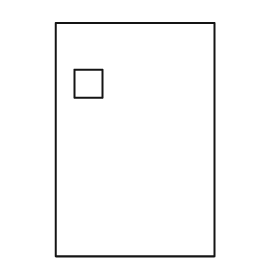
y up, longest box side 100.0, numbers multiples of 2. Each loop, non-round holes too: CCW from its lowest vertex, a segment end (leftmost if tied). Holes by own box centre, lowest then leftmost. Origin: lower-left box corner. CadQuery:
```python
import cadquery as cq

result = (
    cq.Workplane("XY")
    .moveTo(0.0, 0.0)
    .lineTo(68.0, 0.0)
    .lineTo(68.0, 100.0)
    .lineTo(0.0, 100.0)
    .close()
    .moveTo(8.0, 68.0)
    .lineTo(20.0, 68.0)
    .lineTo(20.0, 80.0)
    .lineTo(8.0, 80.0)
    .close()
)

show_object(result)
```